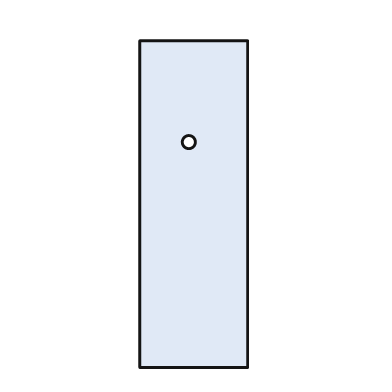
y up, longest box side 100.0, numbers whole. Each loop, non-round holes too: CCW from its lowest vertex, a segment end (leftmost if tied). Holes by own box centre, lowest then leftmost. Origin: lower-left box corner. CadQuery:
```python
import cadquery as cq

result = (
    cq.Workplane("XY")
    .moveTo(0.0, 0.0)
    .lineTo(33.0, 0.0)
    .lineTo(33.0, 100.0)
    .lineTo(0.0, 100.0)
    .close()
    .moveTo(15.0, 69.0)
    .circle(2.0)
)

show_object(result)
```